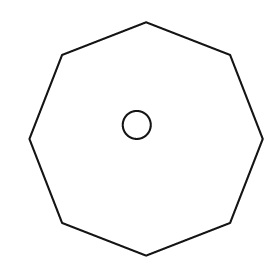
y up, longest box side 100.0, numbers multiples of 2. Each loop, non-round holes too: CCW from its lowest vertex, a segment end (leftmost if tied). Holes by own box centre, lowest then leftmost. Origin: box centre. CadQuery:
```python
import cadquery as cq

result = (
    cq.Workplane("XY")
    .moveTo(0.0, -50.0)
    .lineTo(36.0, -36.0)
    .lineTo(50.0, 0.0)
    .lineTo(36.0, 36.0)
    .lineTo(0.0, 50.0)
    .lineTo(-36.0, 36.0)
    .lineTo(-50.0, 0.0)
    .lineTo(-36.0, -36.0)
    .close()
    .moveTo(-4.0, 6.0)
    .circle(6.0)
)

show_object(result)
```